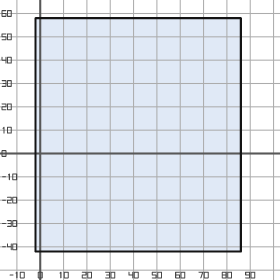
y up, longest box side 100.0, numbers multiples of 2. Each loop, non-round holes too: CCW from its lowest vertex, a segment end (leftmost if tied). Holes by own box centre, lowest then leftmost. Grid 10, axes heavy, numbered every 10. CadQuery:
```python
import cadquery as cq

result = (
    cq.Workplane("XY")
    .moveTo(-2.0, -42.0)
    .lineTo(86.0, -42.0)
    .lineTo(86.0, 58.0)
    .lineTo(-2.0, 58.0)
    .close()
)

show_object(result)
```